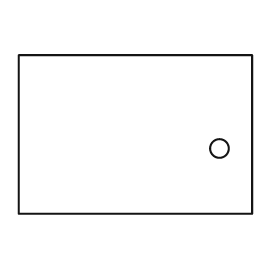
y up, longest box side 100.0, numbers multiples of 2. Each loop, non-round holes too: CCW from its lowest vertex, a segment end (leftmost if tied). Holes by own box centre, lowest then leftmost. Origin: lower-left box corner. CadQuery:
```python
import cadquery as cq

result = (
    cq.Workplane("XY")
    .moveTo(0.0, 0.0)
    .lineTo(100.0, 0.0)
    .lineTo(100.0, 68.0)
    .lineTo(0.0, 68.0)
    .close()
    .moveTo(86.0, 28.0)
    .circle(4.0)
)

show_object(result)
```